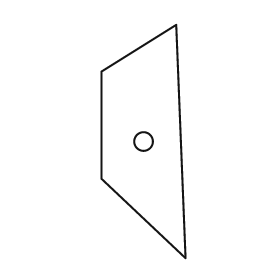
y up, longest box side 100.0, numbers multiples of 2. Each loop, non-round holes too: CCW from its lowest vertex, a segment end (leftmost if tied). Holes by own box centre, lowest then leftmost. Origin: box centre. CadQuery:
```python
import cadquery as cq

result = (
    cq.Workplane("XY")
    .moveTo(18.0, -50.0)
    .lineTo(14.0, 50.0)
    .lineTo(-18.0, 30.0)
    .lineTo(-18.0, -16.0)
    .close()
    .moveTo(0.0, 0.0)
    .circle(4.0)
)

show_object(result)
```